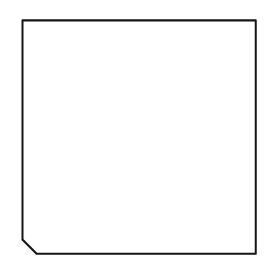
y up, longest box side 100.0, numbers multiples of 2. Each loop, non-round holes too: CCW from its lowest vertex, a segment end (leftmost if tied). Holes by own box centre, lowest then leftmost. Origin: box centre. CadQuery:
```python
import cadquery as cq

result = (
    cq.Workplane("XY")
    .moveTo(-44.0, -50.0)
    .lineTo(50.0, -50.0)
    .lineTo(50.0, 50.0)
    .lineTo(-50.0, 50.0)
    .lineTo(-50.0, -44.0)
    .close()
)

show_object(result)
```